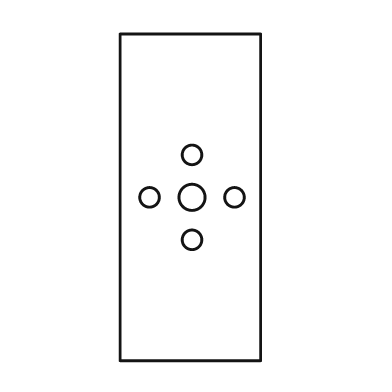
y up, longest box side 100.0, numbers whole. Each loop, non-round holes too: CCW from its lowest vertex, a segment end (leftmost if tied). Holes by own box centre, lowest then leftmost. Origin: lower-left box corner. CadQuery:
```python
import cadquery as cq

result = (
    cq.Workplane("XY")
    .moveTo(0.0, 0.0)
    .lineTo(43.0, 0.0)
    .lineTo(43.0, 100.0)
    .lineTo(0.0, 100.0)
    .close()
    .moveTo(22.0, 37.0)
    .circle(3.0)
    .moveTo(9.0, 50.0)
    .circle(3.0)
    .moveTo(22.0, 50.0)
    .circle(4.0)
    .moveTo(35.0, 50.0)
    .circle(3.0)
    .moveTo(22.0, 63.0)
    .circle(3.0)
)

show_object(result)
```